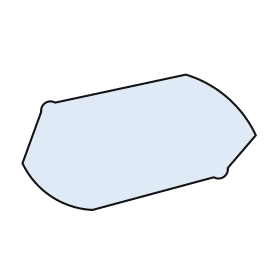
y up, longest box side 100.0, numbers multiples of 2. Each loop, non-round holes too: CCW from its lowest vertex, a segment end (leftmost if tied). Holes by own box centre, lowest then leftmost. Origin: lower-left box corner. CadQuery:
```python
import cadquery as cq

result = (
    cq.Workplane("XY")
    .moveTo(30.0, 0.0)
    .lineTo(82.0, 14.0)
    .threePointArc((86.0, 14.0), (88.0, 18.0))
    .lineTo(100.0, 32.0)
    .threePointArc((88.0, 48.0), (70.0, 58.0))
    .lineTo(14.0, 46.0)
    .threePointArc((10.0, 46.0), (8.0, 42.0))
    .lineTo(0.0, 20.0)
    .threePointArc((12.0, 6.0), (30.0, 0.0))
    .close()
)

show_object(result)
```